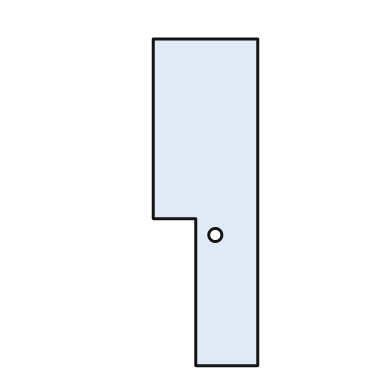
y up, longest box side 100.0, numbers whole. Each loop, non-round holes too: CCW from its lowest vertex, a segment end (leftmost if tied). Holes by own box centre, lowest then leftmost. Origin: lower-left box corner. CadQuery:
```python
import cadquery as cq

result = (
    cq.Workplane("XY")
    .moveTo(13.0, 0.0)
    .lineTo(32.0, 0.0)
    .lineTo(32.0, 100.0)
    .lineTo(0.0, 100.0)
    .lineTo(0.0, 45.0)
    .lineTo(13.0, 45.0)
    .close()
    .moveTo(19.0, 40.0)
    .circle(2.0)
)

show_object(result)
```